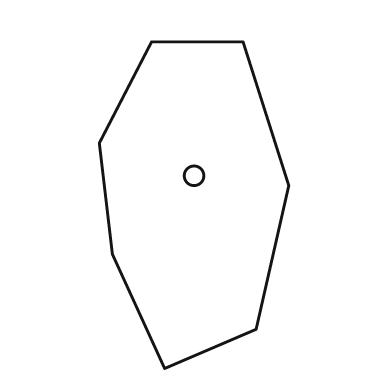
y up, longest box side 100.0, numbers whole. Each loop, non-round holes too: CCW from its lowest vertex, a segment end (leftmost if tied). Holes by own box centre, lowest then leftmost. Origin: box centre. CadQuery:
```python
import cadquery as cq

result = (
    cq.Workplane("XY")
    .moveTo(-9.0, -50.0)
    .lineTo(19.0, -38.0)
    .lineTo(29.0, 6.0)
    .lineTo(15.0, 50.0)
    .lineTo(-13.0, 50.0)
    .lineTo(-29.0, 19.0)
    .lineTo(-25.0, -15.0)
    .close()
    .moveTo(0.0, 9.0)
    .circle(3.0)
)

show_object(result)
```